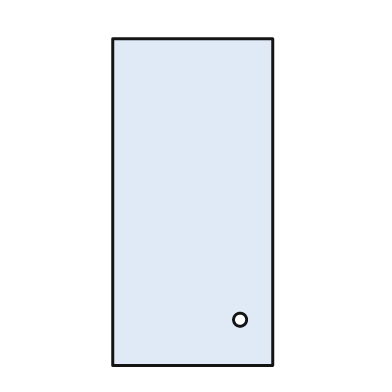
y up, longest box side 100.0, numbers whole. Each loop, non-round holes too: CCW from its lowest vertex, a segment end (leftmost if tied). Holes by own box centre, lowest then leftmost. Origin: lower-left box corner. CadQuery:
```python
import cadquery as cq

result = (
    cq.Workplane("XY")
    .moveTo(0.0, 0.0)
    .lineTo(49.0, 0.0)
    .lineTo(49.0, 100.0)
    .lineTo(0.0, 100.0)
    .close()
    .moveTo(39.0, 14.0)
    .circle(2.0)
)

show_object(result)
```